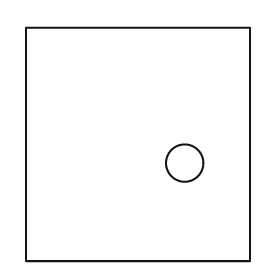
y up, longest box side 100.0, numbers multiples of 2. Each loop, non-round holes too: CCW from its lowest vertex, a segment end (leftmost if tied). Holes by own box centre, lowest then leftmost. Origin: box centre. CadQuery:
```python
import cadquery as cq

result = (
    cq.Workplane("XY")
    .moveTo(-48.0, -50.0)
    .lineTo(48.0, -50.0)
    .lineTo(48.0, 50.0)
    .lineTo(-48.0, 50.0)
    .close()
    .moveTo(20.0, -8.0)
    .circle(8.0)
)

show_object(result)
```